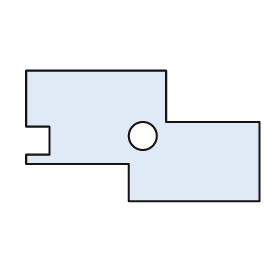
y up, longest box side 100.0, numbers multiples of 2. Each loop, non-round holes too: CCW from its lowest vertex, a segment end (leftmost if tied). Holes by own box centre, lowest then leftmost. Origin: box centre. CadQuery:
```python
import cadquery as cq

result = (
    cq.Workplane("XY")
    .moveTo(-6.0, -28.0)
    .lineTo(50.0, -28.0)
    .lineTo(50.0, 6.0)
    .lineTo(10.0, 6.0)
    .lineTo(10.0, 28.0)
    .lineTo(-50.0, 28.0)
    .lineTo(-50.0, 4.0)
    .lineTo(-40.0, 4.0)
    .lineTo(-40.0, -8.0)
    .lineTo(-50.0, -8.0)
    .lineTo(-50.0, -12.0)
    .lineTo(-6.0, -12.0)
    .close()
    .moveTo(0.0, 0.0)
    .circle(6.0)
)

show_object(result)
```